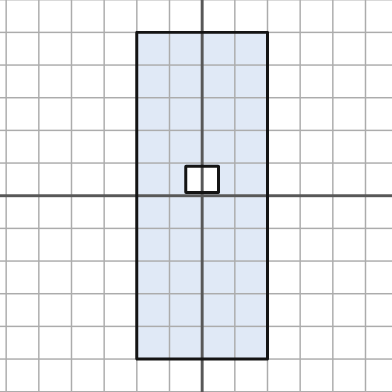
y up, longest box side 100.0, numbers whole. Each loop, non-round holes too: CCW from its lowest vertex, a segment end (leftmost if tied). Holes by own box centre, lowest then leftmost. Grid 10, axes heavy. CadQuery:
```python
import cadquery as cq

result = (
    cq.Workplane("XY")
    .moveTo(-20.0, -50.0)
    .lineTo(20.0, -50.0)
    .lineTo(20.0, 50.0)
    .lineTo(-20.0, 50.0)
    .close()
    .moveTo(-5.0, 1.0)
    .lineTo(5.0, 1.0)
    .lineTo(5.0, 9.0)
    .lineTo(-5.0, 9.0)
    .close()
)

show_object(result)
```